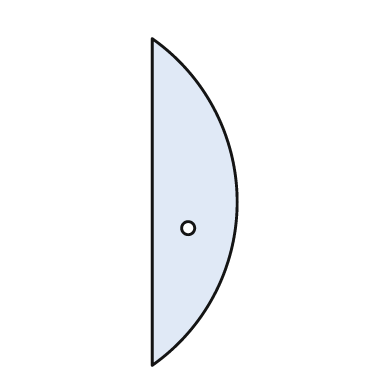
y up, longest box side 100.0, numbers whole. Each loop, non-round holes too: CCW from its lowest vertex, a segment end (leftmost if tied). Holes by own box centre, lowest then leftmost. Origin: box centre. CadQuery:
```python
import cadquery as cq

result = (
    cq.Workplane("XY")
    .moveTo(-13.0, -50.0)
    .threePointArc((13.0, 0.0), (-13.0, 50.0))
    .close()
    .moveTo(-2.0, -8.0)
    .circle(2.0)
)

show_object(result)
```